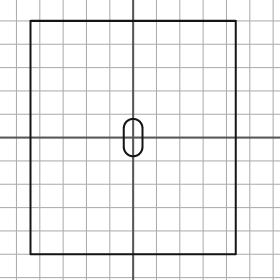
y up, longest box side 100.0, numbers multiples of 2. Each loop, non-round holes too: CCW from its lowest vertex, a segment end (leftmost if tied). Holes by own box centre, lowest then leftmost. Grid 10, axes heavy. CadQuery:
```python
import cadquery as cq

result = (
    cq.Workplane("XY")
    .moveTo(-44.0, -50.0)
    .lineTo(44.0, -50.0)
    .lineTo(44.0, 50.0)
    .lineTo(-44.0, 50.0)
    .close()
    .moveTo(-4.0, -4.0)
    .threePointArc((0.0, -8.0), (4.0, -4.0))
    .lineTo(4.0, 4.0)
    .threePointArc((0.0, 8.0), (-4.0, 4.0))
    .close()
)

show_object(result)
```